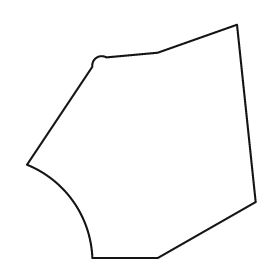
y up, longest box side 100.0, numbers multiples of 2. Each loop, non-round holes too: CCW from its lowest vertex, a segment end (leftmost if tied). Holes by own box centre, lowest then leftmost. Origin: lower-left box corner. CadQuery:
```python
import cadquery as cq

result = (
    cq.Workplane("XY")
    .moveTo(28.0, 0.0)
    .lineTo(56.0, 0.0)
    .lineTo(98.0, 24.0)
    .lineTo(90.0, 100.0)
    .lineTo(56.0, 88.0)
    .lineTo(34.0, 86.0)
    .threePointArc((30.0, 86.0), (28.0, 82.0))
    .lineTo(0.0, 40.0)
    .threePointArc((20.0, 24.0), (28.0, 0.0))
    .close()
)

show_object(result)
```